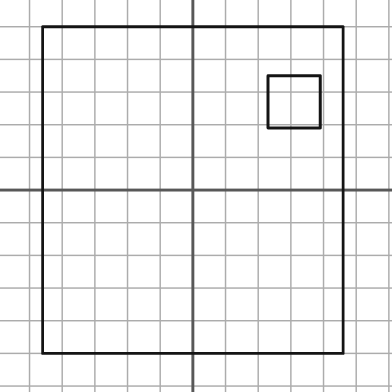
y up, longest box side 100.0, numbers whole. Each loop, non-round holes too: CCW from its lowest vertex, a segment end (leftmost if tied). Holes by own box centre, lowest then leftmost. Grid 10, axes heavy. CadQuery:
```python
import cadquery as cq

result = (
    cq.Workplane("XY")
    .moveTo(-46.0, -50.0)
    .lineTo(46.0, -50.0)
    .lineTo(46.0, 50.0)
    .lineTo(-46.0, 50.0)
    .close()
    .moveTo(23.0, 19.0)
    .lineTo(39.0, 19.0)
    .lineTo(39.0, 35.0)
    .lineTo(23.0, 35.0)
    .close()
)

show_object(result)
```